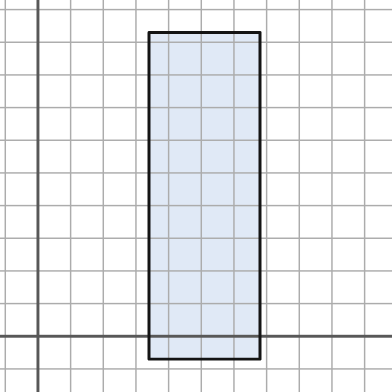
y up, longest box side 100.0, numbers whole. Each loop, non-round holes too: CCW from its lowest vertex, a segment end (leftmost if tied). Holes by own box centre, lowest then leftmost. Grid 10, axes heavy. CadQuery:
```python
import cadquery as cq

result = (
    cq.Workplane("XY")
    .moveTo(34.0, -7.0)
    .lineTo(68.0, -7.0)
    .lineTo(68.0, 93.0)
    .lineTo(34.0, 93.0)
    .close()
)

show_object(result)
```